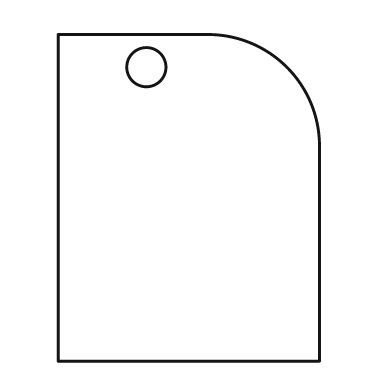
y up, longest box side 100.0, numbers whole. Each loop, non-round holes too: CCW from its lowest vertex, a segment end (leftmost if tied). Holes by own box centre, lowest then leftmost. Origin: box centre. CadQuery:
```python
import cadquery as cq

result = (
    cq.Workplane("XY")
    .moveTo(-40.0, -50.0)
    .lineTo(40.0, -50.0)
    .lineTo(40.0, 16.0)
    .threePointArc((30.0, 40.0), (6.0, 50.0))
    .lineTo(-40.0, 50.0)
    .close()
    .moveTo(-13.0, 40.0)
    .circle(6.0)
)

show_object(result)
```